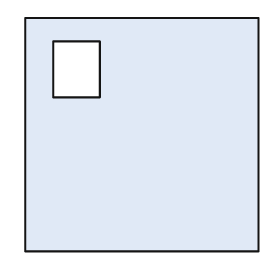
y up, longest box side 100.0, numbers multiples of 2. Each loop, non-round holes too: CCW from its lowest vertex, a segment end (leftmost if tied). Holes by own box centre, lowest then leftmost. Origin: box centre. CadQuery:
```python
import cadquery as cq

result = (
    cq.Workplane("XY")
    .moveTo(-50.0, -50.0)
    .lineTo(50.0, -50.0)
    .lineTo(50.0, 50.0)
    .lineTo(-50.0, 50.0)
    .close()
    .moveTo(-38.0, 16.0)
    .lineTo(-18.0, 16.0)
    .lineTo(-18.0, 40.0)
    .lineTo(-38.0, 40.0)
    .close()
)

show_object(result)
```